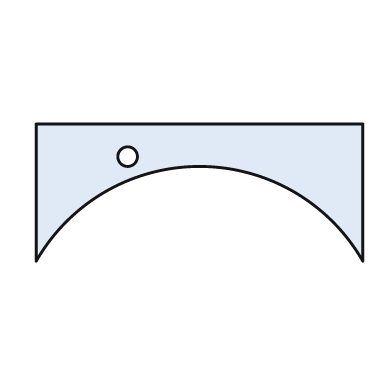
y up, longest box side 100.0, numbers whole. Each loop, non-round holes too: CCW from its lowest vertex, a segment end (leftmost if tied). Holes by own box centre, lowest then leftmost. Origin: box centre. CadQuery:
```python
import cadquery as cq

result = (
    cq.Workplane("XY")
    .moveTo(-50.0, -21.0)
    .threePointArc((0.0, 8.0), (50.0, -21.0))
    .lineTo(50.0, 21.0)
    .lineTo(-50.0, 21.0)
    .close()
    .moveTo(-22.0, 11.0)
    .circle(3.0)
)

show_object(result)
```